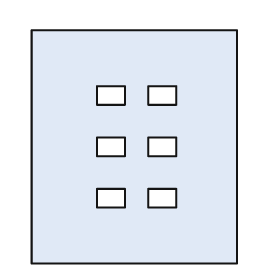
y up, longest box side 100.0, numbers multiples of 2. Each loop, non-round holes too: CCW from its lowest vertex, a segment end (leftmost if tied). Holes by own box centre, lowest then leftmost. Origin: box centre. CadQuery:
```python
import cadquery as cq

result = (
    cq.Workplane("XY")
    .moveTo(-44.0, -50.0)
    .lineTo(44.0, -50.0)
    .lineTo(44.0, 50.0)
    .lineTo(-44.0, 50.0)
    .close()
    .moveTo(-16.0, -26.0)
    .lineTo(-4.0, -26.0)
    .lineTo(-4.0, -18.0)
    .lineTo(-16.0, -18.0)
    .close()
    .moveTo(6.0, -26.0)
    .lineTo(18.0, -26.0)
    .lineTo(18.0, -18.0)
    .lineTo(6.0, -18.0)
    .close()
    .moveTo(-16.0, -4.0)
    .lineTo(-4.0, -4.0)
    .lineTo(-4.0, 4.0)
    .lineTo(-16.0, 4.0)
    .close()
    .moveTo(6.0, -4.0)
    .lineTo(18.0, -4.0)
    .lineTo(18.0, 4.0)
    .lineTo(6.0, 4.0)
    .close()
    .moveTo(-16.0, 18.0)
    .lineTo(-4.0, 18.0)
    .lineTo(-4.0, 26.0)
    .lineTo(-16.0, 26.0)
    .close()
    .moveTo(6.0, 18.0)
    .lineTo(18.0, 18.0)
    .lineTo(18.0, 26.0)
    .lineTo(6.0, 26.0)
    .close()
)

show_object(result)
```